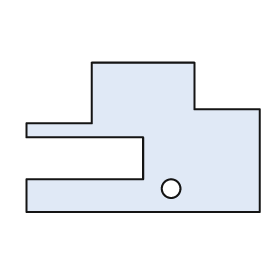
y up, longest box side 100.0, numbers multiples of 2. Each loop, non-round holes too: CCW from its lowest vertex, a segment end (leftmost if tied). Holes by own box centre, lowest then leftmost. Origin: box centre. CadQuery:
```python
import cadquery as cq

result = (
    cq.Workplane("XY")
    .moveTo(-50.0, -32.0)
    .lineTo(50.0, -32.0)
    .lineTo(50.0, 12.0)
    .lineTo(22.0, 12.0)
    .lineTo(22.0, 32.0)
    .lineTo(-22.0, 32.0)
    .lineTo(-22.0, 6.0)
    .lineTo(-50.0, 6.0)
    .lineTo(-50.0, 0.0)
    .lineTo(0.0, 0.0)
    .lineTo(0.0, -18.0)
    .lineTo(-50.0, -18.0)
    .close()
    .moveTo(12.0, -22.0)
    .circle(4.0)
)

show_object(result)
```